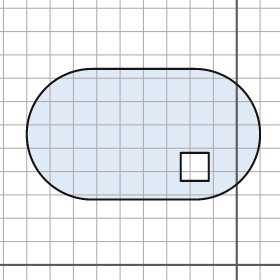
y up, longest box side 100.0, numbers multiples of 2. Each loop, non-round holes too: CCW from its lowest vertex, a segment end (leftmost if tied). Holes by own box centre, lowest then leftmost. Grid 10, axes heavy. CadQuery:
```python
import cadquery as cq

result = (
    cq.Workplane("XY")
    .moveTo(-62.0, 28.0)
    .lineTo(-18.0, 28.0)
    .threePointArc((10.0, 56.0), (-18.0, 84.0))
    .lineTo(-62.0, 84.0)
    .threePointArc((-90.0, 56.0), (-62.0, 28.0))
    .close()
    .moveTo(-24.0, 36.0)
    .lineTo(-12.0, 36.0)
    .lineTo(-12.0, 48.0)
    .lineTo(-24.0, 48.0)
    .close()
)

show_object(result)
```